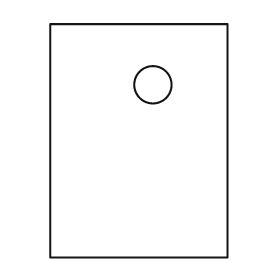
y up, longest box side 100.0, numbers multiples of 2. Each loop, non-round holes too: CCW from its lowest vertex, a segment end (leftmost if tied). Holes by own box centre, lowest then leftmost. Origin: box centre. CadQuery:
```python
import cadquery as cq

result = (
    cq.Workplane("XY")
    .moveTo(-38.0, -50.0)
    .lineTo(38.0, -50.0)
    .lineTo(38.0, 50.0)
    .lineTo(-38.0, 50.0)
    .close()
    .moveTo(6.0, 24.0)
    .circle(8.0)
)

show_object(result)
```